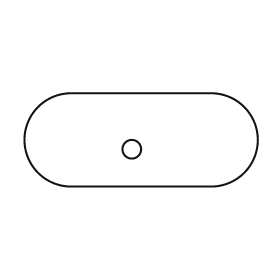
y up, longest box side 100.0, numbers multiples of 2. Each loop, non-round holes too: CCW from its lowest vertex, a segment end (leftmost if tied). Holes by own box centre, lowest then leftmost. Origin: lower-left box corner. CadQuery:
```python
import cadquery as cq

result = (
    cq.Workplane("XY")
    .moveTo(20.0, 0.0)
    .lineTo(80.0, 0.0)
    .threePointArc((100.0, 20.0), (80.0, 40.0))
    .lineTo(20.0, 40.0)
    .threePointArc((0.0, 20.0), (20.0, 0.0))
    .close()
    .moveTo(46.0, 16.0)
    .circle(4.0)
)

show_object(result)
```